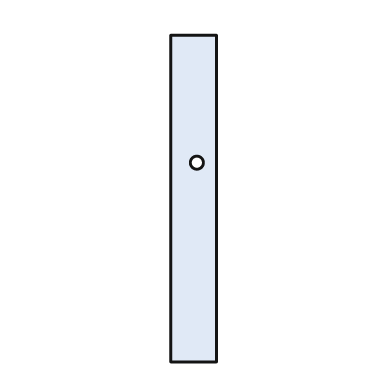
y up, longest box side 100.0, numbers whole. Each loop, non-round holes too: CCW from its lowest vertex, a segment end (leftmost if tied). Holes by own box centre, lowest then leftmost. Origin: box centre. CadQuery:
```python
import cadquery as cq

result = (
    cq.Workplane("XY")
    .moveTo(-7.0, -50.0)
    .lineTo(7.0, -50.0)
    .lineTo(7.0, 50.0)
    .lineTo(-7.0, 50.0)
    .close()
    .moveTo(1.0, 11.0)
    .circle(2.0)
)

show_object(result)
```